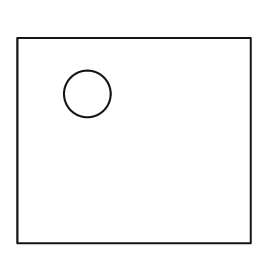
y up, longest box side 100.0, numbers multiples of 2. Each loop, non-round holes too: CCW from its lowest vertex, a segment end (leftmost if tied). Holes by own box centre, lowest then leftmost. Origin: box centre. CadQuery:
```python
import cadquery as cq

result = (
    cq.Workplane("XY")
    .moveTo(-50.0, -44.0)
    .lineTo(50.0, -44.0)
    .lineTo(50.0, 44.0)
    .lineTo(-50.0, 44.0)
    .close()
    .moveTo(-20.0, 20.0)
    .circle(10.0)
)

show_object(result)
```